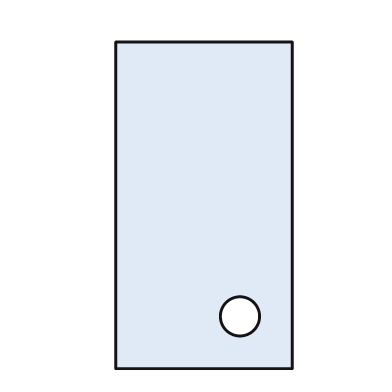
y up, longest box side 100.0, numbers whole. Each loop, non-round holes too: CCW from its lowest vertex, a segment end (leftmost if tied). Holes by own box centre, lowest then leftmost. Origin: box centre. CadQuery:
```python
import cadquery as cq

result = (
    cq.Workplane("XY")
    .moveTo(-27.0, -50.0)
    .lineTo(27.0, -50.0)
    .lineTo(27.0, 50.0)
    .lineTo(-27.0, 50.0)
    .close()
    .moveTo(11.0, -34.0)
    .circle(6.0)
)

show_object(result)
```